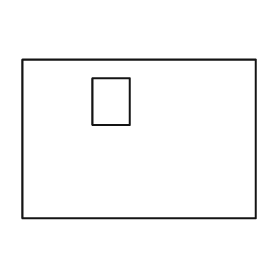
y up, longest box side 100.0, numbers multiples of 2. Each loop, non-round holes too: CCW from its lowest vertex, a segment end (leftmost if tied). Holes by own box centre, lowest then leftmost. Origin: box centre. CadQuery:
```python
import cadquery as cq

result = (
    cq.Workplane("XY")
    .moveTo(-50.0, -34.0)
    .lineTo(50.0, -34.0)
    .lineTo(50.0, 34.0)
    .lineTo(-50.0, 34.0)
    .close()
    .moveTo(-20.0, 6.0)
    .lineTo(-4.0, 6.0)
    .lineTo(-4.0, 26.0)
    .lineTo(-20.0, 26.0)
    .close()
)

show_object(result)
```